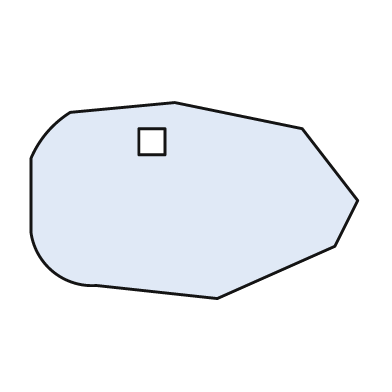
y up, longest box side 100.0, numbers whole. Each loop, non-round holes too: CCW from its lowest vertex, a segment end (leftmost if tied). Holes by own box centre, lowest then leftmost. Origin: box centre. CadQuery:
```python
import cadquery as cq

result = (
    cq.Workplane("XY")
    .moveTo(7.0, -30.0)
    .lineTo(43.0, -14.0)
    .lineTo(50.0, 0.0)
    .lineTo(33.0, 22.0)
    .lineTo(-6.0, 30.0)
    .lineTo(-38.0, 27.0)
    .threePointArc((-45.0, 21.0), (-50.0, 13.0))
    .lineTo(-50.0, -10.0)
    .threePointArc((-43.0, -22.0), (-30.0, -26.0))
    .close()
    .moveTo(-17.0, 14.0)
    .lineTo(-9.0, 14.0)
    .lineTo(-9.0, 22.0)
    .lineTo(-17.0, 22.0)
    .close()
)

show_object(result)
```